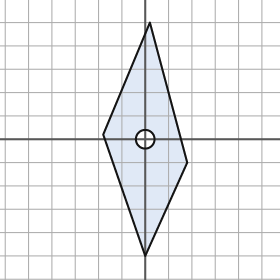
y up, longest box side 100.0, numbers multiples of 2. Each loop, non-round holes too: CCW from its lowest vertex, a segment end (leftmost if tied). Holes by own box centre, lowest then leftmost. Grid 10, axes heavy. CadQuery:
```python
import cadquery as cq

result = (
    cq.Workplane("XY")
    .moveTo(0.0, -50.0)
    .lineTo(18.0, -10.0)
    .lineTo(2.0, 50.0)
    .lineTo(-18.0, 2.0)
    .close()
    .moveTo(0.0, 0.0)
    .circle(4.0)
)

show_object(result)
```